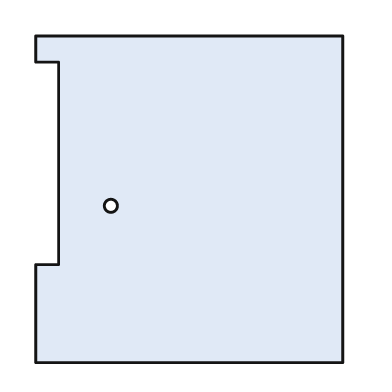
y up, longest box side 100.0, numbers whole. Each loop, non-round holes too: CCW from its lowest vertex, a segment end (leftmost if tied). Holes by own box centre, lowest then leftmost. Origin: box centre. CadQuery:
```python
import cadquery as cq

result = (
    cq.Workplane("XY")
    .moveTo(-47.0, -50.0)
    .lineTo(47.0, -50.0)
    .lineTo(47.0, 50.0)
    .lineTo(-47.0, 50.0)
    .lineTo(-47.0, 42.0)
    .lineTo(-40.0, 42.0)
    .lineTo(-40.0, -20.0)
    .lineTo(-47.0, -20.0)
    .close()
    .moveTo(-24.0, -2.0)
    .circle(2.0)
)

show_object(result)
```